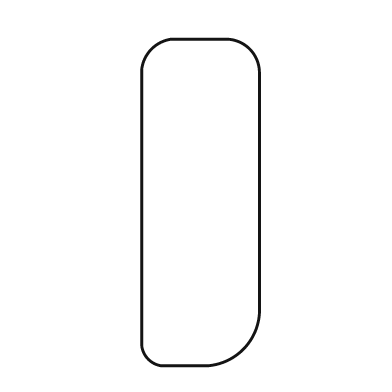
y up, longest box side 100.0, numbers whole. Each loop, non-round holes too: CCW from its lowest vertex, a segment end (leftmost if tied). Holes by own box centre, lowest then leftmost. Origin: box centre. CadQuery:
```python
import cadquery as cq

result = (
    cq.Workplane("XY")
    .moveTo(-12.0, -50.0)
    .lineTo(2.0, -50.0)
    .threePointArc((13.0, -45.0), (18.0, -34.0))
    .lineTo(18.0, 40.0)
    .threePointArc((15.0, 47.0), (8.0, 50.0))
    .lineTo(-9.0, 50.0)
    .threePointArc((-15.0, 47.0), (-18.0, 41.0))
    .lineTo(-18.0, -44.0)
    .threePointArc((-16.0, -48.0), (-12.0, -50.0))
    .close()
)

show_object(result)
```